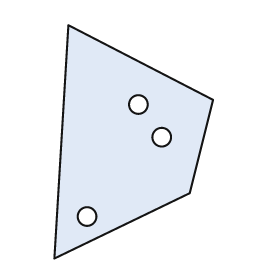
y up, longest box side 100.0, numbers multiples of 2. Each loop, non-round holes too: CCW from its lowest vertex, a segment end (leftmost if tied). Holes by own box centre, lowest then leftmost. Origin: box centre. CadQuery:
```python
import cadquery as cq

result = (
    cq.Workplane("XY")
    .moveTo(-34.0, -50.0)
    .lineTo(24.0, -22.0)
    .lineTo(34.0, 18.0)
    .lineTo(-28.0, 50.0)
    .close()
    .moveTo(-20.0, -32.0)
    .circle(4.0)
    .moveTo(12.0, 2.0)
    .circle(4.0)
    .moveTo(2.0, 16.0)
    .circle(4.0)
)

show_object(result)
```